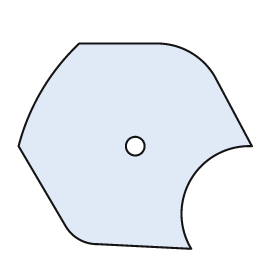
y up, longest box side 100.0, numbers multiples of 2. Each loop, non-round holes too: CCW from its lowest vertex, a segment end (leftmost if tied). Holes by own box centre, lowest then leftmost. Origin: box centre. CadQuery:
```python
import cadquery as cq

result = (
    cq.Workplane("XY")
    .moveTo(24.0, -44.0)
    .threePointArc((24.0, -14.0), (50.0, 0.0))
    .lineTo(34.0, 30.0)
    .threePointArc((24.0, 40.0), (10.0, 44.0))
    .lineTo(-24.0, 44.0)
    .threePointArc((-40.0, 24.0), (-50.0, 0.0))
    .lineTo(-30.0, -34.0)
    .threePointArc((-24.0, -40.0), (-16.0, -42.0))
    .close()
    .moveTo(0.0, 0.0)
    .circle(4.0)
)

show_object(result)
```